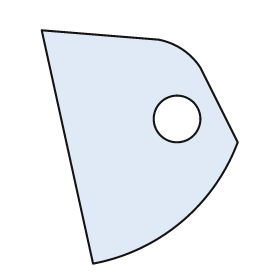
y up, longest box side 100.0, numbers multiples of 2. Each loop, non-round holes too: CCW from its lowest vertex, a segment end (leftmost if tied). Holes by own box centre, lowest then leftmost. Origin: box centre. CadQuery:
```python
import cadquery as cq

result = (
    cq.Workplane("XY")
    .moveTo(-20.0, -50.0)
    .threePointArc((18.0, -32.0), (42.0, 2.0))
    .lineTo(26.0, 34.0)
    .threePointArc((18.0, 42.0), (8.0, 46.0))
    .lineTo(-42.0, 50.0)
    .close()
    .moveTo(16.0, 12.0)
    .circle(10.0)
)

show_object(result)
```